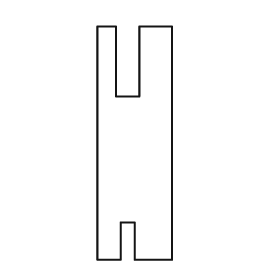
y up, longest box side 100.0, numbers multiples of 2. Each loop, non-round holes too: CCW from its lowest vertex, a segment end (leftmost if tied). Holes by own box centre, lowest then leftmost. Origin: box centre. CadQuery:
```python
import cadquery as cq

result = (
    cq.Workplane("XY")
    .moveTo(-16.0, -50.0)
    .lineTo(-6.0, -50.0)
    .lineTo(-6.0, -34.0)
    .lineTo(0.0, -34.0)
    .lineTo(0.0, -50.0)
    .lineTo(16.0, -50.0)
    .lineTo(16.0, 50.0)
    .lineTo(2.0, 50.0)
    .lineTo(2.0, 20.0)
    .lineTo(-8.0, 20.0)
    .lineTo(-8.0, 50.0)
    .lineTo(-16.0, 50.0)
    .close()
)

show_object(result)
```